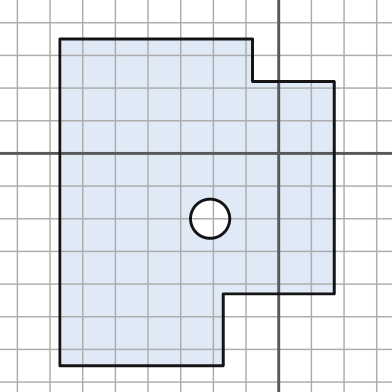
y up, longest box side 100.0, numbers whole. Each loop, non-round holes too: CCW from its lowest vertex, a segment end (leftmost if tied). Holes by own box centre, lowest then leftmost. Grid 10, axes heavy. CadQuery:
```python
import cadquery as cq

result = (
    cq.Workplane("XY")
    .moveTo(-67.0, -65.0)
    .lineTo(-17.0, -65.0)
    .lineTo(-17.0, -43.0)
    .lineTo(17.0, -43.0)
    .lineTo(17.0, 22.0)
    .lineTo(-8.0, 22.0)
    .lineTo(-8.0, 35.0)
    .lineTo(-67.0, 35.0)
    .close()
    .moveTo(-21.0, -20.0)
    .circle(6.0)
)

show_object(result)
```